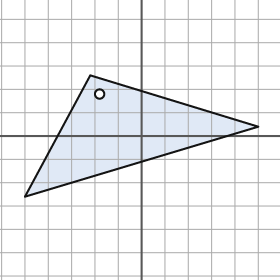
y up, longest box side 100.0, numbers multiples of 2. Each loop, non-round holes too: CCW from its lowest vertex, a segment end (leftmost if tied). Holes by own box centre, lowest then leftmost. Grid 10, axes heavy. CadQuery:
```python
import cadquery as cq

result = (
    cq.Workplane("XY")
    .moveTo(-50.0, -26.0)
    .lineTo(50.0, 4.0)
    .lineTo(-22.0, 26.0)
    .close()
    .moveTo(-18.0, 18.0)
    .circle(2.0)
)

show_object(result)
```